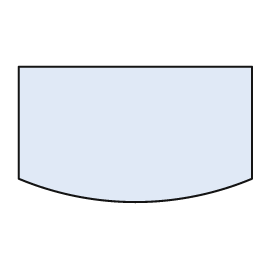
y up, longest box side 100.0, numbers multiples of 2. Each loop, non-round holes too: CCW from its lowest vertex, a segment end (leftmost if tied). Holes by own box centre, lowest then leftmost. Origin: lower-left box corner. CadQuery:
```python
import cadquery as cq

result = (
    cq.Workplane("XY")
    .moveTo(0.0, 10.0)
    .threePointArc((50.0, 0.0), (100.0, 10.0))
    .lineTo(100.0, 58.0)
    .lineTo(0.0, 58.0)
    .close()
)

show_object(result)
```